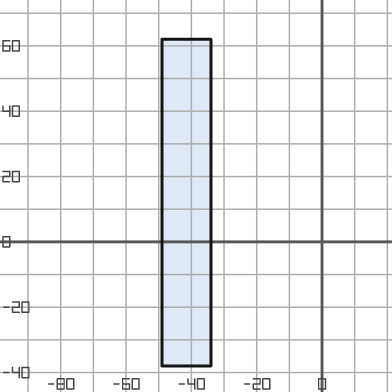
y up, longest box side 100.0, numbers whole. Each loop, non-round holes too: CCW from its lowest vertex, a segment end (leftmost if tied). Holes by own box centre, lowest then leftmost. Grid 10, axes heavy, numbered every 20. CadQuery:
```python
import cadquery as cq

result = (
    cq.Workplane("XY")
    .moveTo(-49.0, -38.0)
    .lineTo(-34.0, -38.0)
    .lineTo(-34.0, 62.0)
    .lineTo(-49.0, 62.0)
    .close()
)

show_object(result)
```